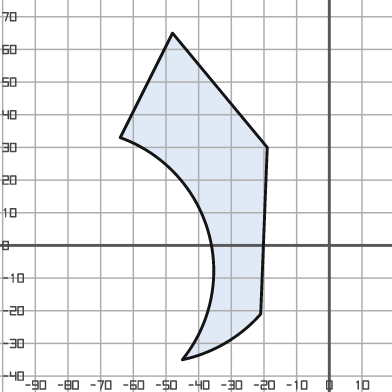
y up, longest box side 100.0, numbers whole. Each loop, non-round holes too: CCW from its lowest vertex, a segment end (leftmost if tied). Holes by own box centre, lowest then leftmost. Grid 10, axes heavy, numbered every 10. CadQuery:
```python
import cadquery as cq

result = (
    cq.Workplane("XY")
    .moveTo(-45.0, -35.0)
    .threePointArc((-32.0, -30.0), (-21.0, -21.0))
    .lineTo(-19.0, 30.0)
    .lineTo(-48.0, 65.0)
    .lineTo(-64.0, 33.0)
    .threePointArc((-37.0, 4.0), (-45.0, -35.0))
    .close()
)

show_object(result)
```